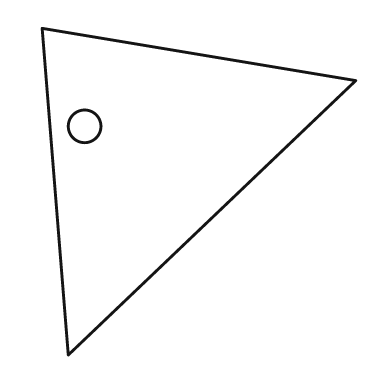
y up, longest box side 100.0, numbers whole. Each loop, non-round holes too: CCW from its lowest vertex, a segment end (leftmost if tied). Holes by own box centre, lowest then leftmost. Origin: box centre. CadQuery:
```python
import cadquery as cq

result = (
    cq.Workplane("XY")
    .moveTo(-40.0, -50.0)
    .lineTo(48.0, 34.0)
    .lineTo(-48.0, 50.0)
    .close()
    .moveTo(-35.0, 20.0)
    .circle(5.0)
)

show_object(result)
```